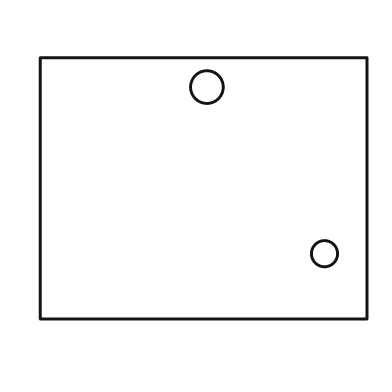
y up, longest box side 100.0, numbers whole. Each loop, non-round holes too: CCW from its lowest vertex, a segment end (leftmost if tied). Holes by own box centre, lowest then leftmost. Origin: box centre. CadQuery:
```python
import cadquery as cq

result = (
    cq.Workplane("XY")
    .moveTo(-50.0, -40.0)
    .lineTo(50.0, -40.0)
    .lineTo(50.0, 40.0)
    .lineTo(-50.0, 40.0)
    .close()
    .moveTo(37.0, -20.0)
    .circle(4.0)
    .moveTo(1.0, 31.0)
    .circle(5.0)
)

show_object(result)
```